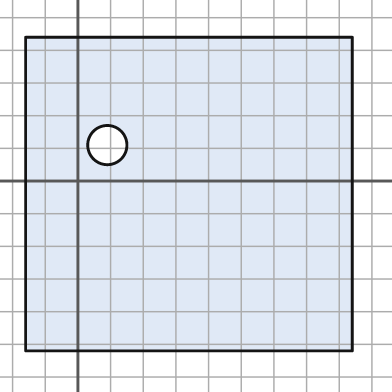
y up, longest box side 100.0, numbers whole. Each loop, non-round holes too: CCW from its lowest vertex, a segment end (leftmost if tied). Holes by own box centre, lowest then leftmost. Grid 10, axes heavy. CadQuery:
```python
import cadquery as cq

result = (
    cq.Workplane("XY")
    .moveTo(-16.0, -52.0)
    .lineTo(84.0, -52.0)
    .lineTo(84.0, 44.0)
    .lineTo(-16.0, 44.0)
    .close()
    .moveTo(9.0, 11.0)
    .circle(6.0)
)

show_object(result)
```